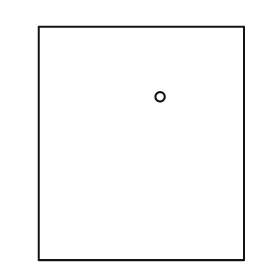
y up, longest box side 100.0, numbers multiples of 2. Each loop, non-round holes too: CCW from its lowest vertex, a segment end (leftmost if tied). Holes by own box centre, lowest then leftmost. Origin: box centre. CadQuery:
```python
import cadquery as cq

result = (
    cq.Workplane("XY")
    .moveTo(-44.0, -50.0)
    .lineTo(44.0, -50.0)
    .lineTo(44.0, 50.0)
    .lineTo(-44.0, 50.0)
    .close()
    .moveTo(8.0, 20.0)
    .circle(2.0)
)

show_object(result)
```